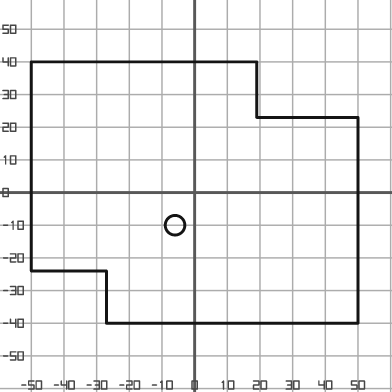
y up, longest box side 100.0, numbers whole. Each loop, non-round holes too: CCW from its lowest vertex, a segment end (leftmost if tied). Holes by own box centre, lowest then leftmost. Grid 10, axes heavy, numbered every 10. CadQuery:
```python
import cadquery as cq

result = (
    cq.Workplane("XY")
    .moveTo(-27.0, -40.0)
    .lineTo(50.0, -40.0)
    .lineTo(50.0, 23.0)
    .lineTo(19.0, 23.0)
    .lineTo(19.0, 40.0)
    .lineTo(-50.0, 40.0)
    .lineTo(-50.0, -24.0)
    .lineTo(-27.0, -24.0)
    .close()
    .moveTo(-6.0, -10.0)
    .circle(3.0)
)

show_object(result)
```